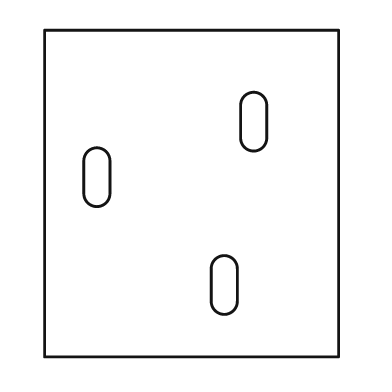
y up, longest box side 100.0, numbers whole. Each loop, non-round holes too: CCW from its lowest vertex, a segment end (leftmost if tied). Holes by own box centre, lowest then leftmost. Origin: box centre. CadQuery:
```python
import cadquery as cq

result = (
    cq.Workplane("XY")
    .moveTo(-45.0, -50.0)
    .lineTo(45.0, -50.0)
    .lineTo(45.0, 50.0)
    .lineTo(-45.0, 50.0)
    .close()
    .moveTo(6.0, -33.0)
    .threePointArc((10.0, -37.0), (14.0, -33.0))
    .lineTo(14.0, -23.0)
    .threePointArc((10.0, -19.0), (6.0, -23.0))
    .close()
    .moveTo(-33.0, 0.0)
    .threePointArc((-29.0, -4.0), (-25.0, 0.0))
    .lineTo(-25.0, 10.0)
    .threePointArc((-29.0, 14.0), (-33.0, 10.0))
    .close()
    .moveTo(15.0, 17.0)
    .threePointArc((19.0, 13.0), (23.0, 17.0))
    .lineTo(23.0, 27.0)
    .threePointArc((19.0, 31.0), (15.0, 27.0))
    .close()
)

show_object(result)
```